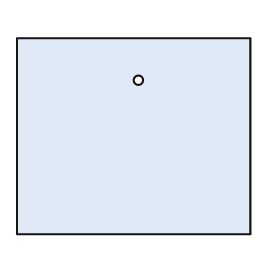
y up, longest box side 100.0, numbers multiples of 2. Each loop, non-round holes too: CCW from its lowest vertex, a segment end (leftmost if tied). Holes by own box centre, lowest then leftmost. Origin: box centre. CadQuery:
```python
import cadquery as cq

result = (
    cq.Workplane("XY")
    .moveTo(-50.0, -42.0)
    .lineTo(50.0, -42.0)
    .lineTo(50.0, 42.0)
    .lineTo(-50.0, 42.0)
    .close()
    .moveTo(2.0, 24.0)
    .circle(2.0)
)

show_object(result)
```